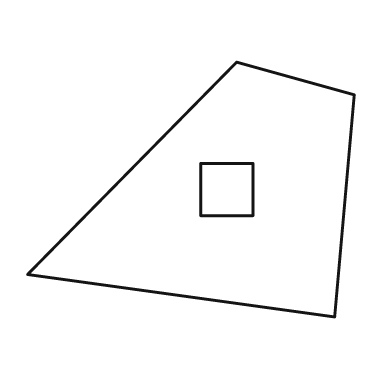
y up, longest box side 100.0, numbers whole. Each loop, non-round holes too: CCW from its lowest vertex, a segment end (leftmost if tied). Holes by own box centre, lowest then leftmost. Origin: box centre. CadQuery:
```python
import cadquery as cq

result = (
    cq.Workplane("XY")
    .moveTo(44.0, -39.0)
    .lineTo(50.0, 29.0)
    .lineTo(14.0, 39.0)
    .lineTo(-50.0, -26.0)
    .close()
    .moveTo(3.0, -8.0)
    .lineTo(19.0, -8.0)
    .lineTo(19.0, 8.0)
    .lineTo(3.0, 8.0)
    .close()
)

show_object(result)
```